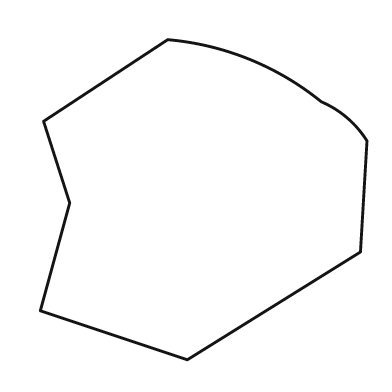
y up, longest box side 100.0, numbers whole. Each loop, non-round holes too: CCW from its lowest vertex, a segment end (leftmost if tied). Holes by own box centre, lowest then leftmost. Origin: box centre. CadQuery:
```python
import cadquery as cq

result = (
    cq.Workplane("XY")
    .moveTo(-5.0, -49.0)
    .lineTo(48.0, -16.0)
    .lineTo(50.0, 18.0)
    .threePointArc((44.0, 25.0), (36.0, 30.0))
    .threePointArc((14.0, 43.0), (-11.0, 49.0))
    .lineTo(-49.0, 24.0)
    .lineTo(-41.0, -1.0)
    .lineTo(-50.0, -34.0)
    .close()
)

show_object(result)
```